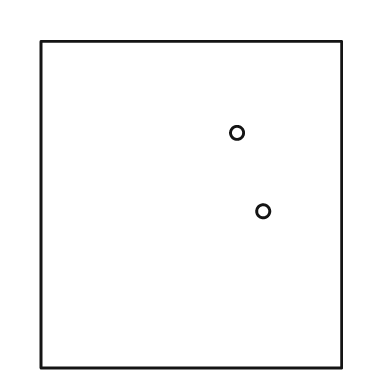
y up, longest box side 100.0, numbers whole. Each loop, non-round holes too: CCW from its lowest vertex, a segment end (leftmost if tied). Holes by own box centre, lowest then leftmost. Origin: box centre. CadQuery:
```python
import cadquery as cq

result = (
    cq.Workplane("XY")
    .moveTo(-46.0, -50.0)
    .lineTo(46.0, -50.0)
    .lineTo(46.0, 50.0)
    .lineTo(-46.0, 50.0)
    .close()
    .moveTo(22.0, -2.0)
    .circle(2.0)
    .moveTo(14.0, 22.0)
    .circle(2.0)
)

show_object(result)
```